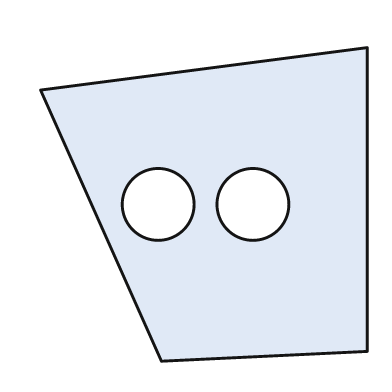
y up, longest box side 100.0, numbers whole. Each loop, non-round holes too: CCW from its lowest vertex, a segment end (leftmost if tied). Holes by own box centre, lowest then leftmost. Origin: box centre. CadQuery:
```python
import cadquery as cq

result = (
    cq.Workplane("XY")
    .moveTo(-13.0, -48.0)
    .lineTo(50.0, -45.0)
    .lineTo(50.0, 48.0)
    .lineTo(-50.0, 35.0)
    .close()
    .moveTo(-14.0, 0.0)
    .circle(11.0)
    .moveTo(15.0, 0.0)
    .circle(11.0)
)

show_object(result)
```